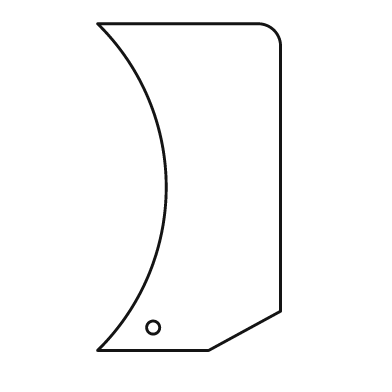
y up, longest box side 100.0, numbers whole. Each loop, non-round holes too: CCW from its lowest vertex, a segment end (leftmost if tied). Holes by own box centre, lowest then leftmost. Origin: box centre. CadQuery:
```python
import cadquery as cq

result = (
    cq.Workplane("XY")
    .moveTo(-28.0, -50.0)
    .lineTo(6.0, -50.0)
    .lineTo(28.0, -38.0)
    .lineTo(28.0, 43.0)
    .threePointArc((26.0, 48.0), (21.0, 50.0))
    .lineTo(-28.0, 50.0)
    .threePointArc((-7.0, 0.0), (-28.0, -50.0))
    .close()
    .moveTo(-11.0, -43.0)
    .circle(2.0)
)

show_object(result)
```